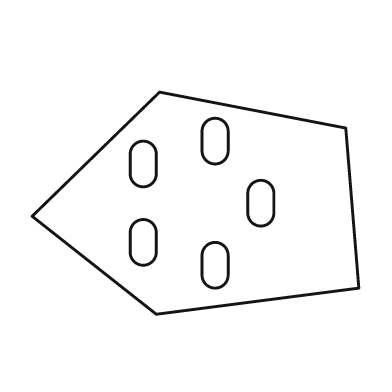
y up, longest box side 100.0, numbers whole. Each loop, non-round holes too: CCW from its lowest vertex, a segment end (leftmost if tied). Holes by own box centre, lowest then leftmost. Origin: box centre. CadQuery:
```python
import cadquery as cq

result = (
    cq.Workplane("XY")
    .moveTo(-12.0, -34.0)
    .lineTo(50.0, -26.0)
    .lineTo(46.0, 23.0)
    .lineTo(-11.0, 34.0)
    .lineTo(-50.0, -4.0)
    .close()
    .moveTo(2.0, -22.0)
    .threePointArc((6.0, -26.0), (10.0, -22.0))
    .lineTo(10.0, -16.0)
    .threePointArc((6.0, -12.0), (2.0, -16.0))
    .close()
    .moveTo(-20.0, -15.0)
    .threePointArc((-16.0, -19.0), (-12.0, -15.0))
    .lineTo(-12.0, -9.0)
    .threePointArc((-16.0, -5.0), (-20.0, -9.0))
    .close()
    .moveTo(16.0, -3.0)
    .threePointArc((20.0, -7.0), (24.0, -3.0))
    .lineTo(24.0, 3.0)
    .threePointArc((20.0, 7.0), (16.0, 3.0))
    .close()
    .moveTo(-20.0, 9.0)
    .threePointArc((-16.0, 5.0), (-12.0, 9.0))
    .lineTo(-12.0, 15.0)
    .threePointArc((-16.0, 19.0), (-20.0, 15.0))
    .close()
    .moveTo(2.0, 16.0)
    .threePointArc((6.0, 12.0), (10.0, 16.0))
    .lineTo(10.0, 22.0)
    .threePointArc((6.0, 26.0), (2.0, 22.0))
    .close()
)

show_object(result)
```